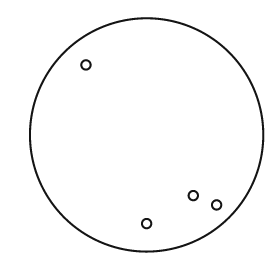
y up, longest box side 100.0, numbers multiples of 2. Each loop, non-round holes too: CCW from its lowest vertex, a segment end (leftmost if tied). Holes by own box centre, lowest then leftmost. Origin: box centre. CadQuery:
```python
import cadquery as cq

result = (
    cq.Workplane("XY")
    .moveTo(0.0, 0.0)
    .circle(50.0)
    .moveTo(0.0, -38.0)
    .circle(2.0)
    .moveTo(30.0, -30.0)
    .circle(2.0)
    .moveTo(20.0, -26.0)
    .circle(2.0)
    .moveTo(-26.0, 30.0)
    .circle(2.0)
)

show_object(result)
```